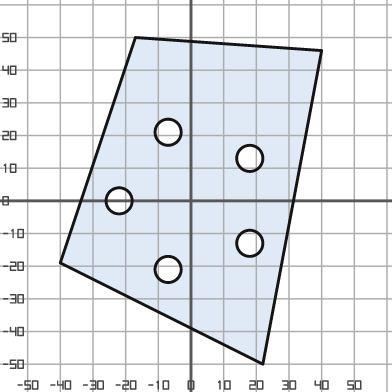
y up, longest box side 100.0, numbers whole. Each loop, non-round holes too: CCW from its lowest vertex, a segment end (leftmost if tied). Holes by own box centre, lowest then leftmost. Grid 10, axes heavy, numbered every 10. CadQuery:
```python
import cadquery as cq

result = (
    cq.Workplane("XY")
    .moveTo(22.0, -50.0)
    .lineTo(40.0, 46.0)
    .lineTo(-17.0, 50.0)
    .lineTo(-40.0, -19.0)
    .close()
    .moveTo(-7.0, -21.0)
    .circle(4.0)
    .moveTo(18.0, -13.0)
    .circle(4.0)
    .moveTo(-22.0, 0.0)
    .circle(4.0)
    .moveTo(18.0, 13.0)
    .circle(4.0)
    .moveTo(-7.0, 21.0)
    .circle(4.0)
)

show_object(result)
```